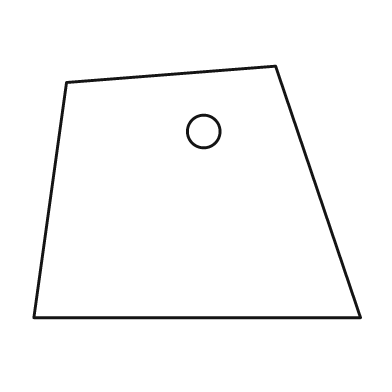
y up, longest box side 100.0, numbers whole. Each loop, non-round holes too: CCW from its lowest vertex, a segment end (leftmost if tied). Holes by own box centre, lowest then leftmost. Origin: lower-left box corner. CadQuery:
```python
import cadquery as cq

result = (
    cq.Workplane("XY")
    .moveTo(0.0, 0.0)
    .lineTo(100.0, 0.0)
    .lineTo(74.0, 77.0)
    .lineTo(10.0, 72.0)
    .close()
    .moveTo(52.0, 57.0)
    .circle(5.0)
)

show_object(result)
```